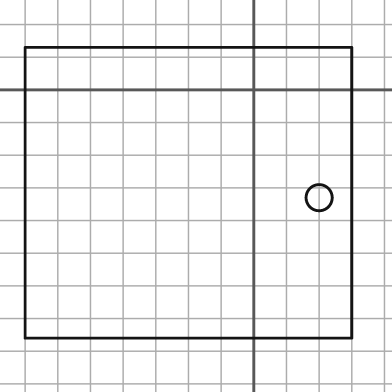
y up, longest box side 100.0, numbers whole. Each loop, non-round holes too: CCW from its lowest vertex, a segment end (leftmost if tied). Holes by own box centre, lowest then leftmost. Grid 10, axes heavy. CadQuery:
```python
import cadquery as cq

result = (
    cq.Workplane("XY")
    .moveTo(-70.0, -76.0)
    .lineTo(30.0, -76.0)
    .lineTo(30.0, 13.0)
    .lineTo(-70.0, 13.0)
    .close()
    .moveTo(20.0, -33.0)
    .circle(4.0)
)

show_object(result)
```